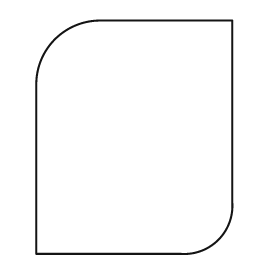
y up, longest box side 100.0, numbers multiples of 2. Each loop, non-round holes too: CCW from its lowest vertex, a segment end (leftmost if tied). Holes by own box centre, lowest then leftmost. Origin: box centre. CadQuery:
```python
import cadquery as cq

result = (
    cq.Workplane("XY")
    .moveTo(-42.0, -50.0)
    .lineTo(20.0, -50.0)
    .threePointArc((36.0, -44.0), (42.0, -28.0))
    .lineTo(42.0, 50.0)
    .lineTo(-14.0, 50.0)
    .threePointArc((-34.0, 42.0), (-42.0, 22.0))
    .close()
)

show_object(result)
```